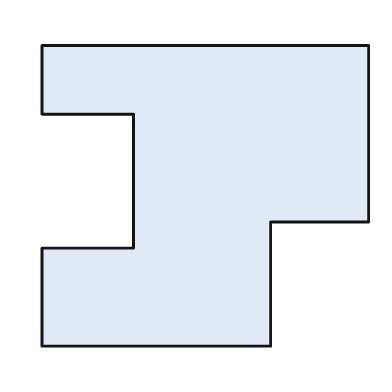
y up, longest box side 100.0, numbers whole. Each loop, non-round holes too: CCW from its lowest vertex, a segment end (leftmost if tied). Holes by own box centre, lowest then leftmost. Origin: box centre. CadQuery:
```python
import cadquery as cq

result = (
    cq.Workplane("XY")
    .moveTo(-50.0, -46.0)
    .lineTo(20.0, -46.0)
    .lineTo(20.0, -8.0)
    .lineTo(50.0, -8.0)
    .lineTo(50.0, 46.0)
    .lineTo(-50.0, 46.0)
    .lineTo(-50.0, 25.0)
    .lineTo(-22.0, 25.0)
    .lineTo(-22.0, -16.0)
    .lineTo(-50.0, -16.0)
    .close()
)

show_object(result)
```